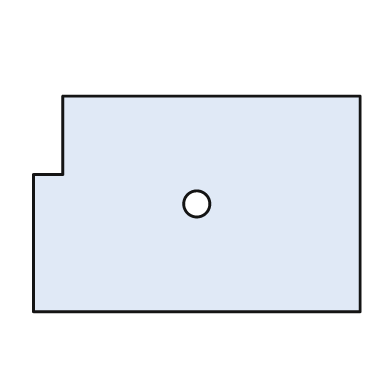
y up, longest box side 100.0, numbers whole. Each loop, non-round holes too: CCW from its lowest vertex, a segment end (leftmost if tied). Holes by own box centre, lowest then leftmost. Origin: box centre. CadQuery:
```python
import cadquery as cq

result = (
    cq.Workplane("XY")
    .moveTo(-50.0, -33.0)
    .lineTo(50.0, -33.0)
    .lineTo(50.0, 33.0)
    .lineTo(-41.0, 33.0)
    .lineTo(-41.0, 9.0)
    .lineTo(-50.0, 9.0)
    .close()
    .moveTo(0.0, 0.0)
    .circle(4.0)
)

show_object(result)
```